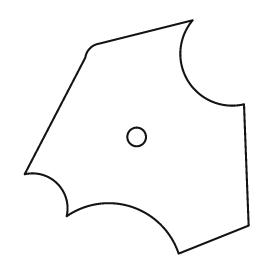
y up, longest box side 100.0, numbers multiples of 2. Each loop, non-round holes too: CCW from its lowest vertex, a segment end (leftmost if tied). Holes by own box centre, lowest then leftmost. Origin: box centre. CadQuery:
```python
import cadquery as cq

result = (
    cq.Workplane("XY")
    .moveTo(18.0, -50.0)
    .lineTo(48.0, -38.0)
    .lineTo(46.0, 14.0)
    .threePointArc((22.0, 24.0), (24.0, 50.0))
    .lineTo(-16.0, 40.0)
    .threePointArc((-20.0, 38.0), (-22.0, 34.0))
    .lineTo(-48.0, -16.0)
    .threePointArc((-34.0, -20.0), (-30.0, -34.0))
    .threePointArc((-2.0, -30.0), (18.0, -50.0))
    .close()
    .moveTo(0.0, 0.0)
    .circle(4.0)
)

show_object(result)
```